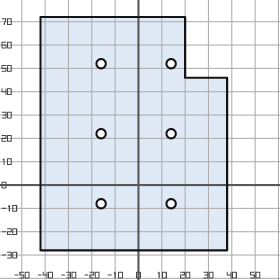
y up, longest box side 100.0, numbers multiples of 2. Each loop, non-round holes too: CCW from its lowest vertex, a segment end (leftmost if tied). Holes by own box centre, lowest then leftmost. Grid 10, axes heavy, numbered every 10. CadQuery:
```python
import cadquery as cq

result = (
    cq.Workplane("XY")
    .moveTo(-42.0, -28.0)
    .lineTo(38.0, -28.0)
    .lineTo(38.0, 46.0)
    .lineTo(20.0, 46.0)
    .lineTo(20.0, 72.0)
    .lineTo(-42.0, 72.0)
    .close()
    .moveTo(-16.0, -8.0)
    .circle(2.0)
    .moveTo(14.0, -8.0)
    .circle(2.0)
    .moveTo(-16.0, 22.0)
    .circle(2.0)
    .moveTo(14.0, 22.0)
    .circle(2.0)
    .moveTo(-16.0, 52.0)
    .circle(2.0)
    .moveTo(14.0, 52.0)
    .circle(2.0)
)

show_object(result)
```